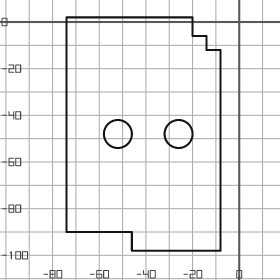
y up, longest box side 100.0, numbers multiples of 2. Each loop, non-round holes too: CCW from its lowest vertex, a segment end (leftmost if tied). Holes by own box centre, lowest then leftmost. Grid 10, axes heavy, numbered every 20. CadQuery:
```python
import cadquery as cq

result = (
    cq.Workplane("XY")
    .moveTo(-46.0, -98.0)
    .lineTo(-8.0, -98.0)
    .lineTo(-8.0, -12.0)
    .lineTo(-14.0, -12.0)
    .lineTo(-14.0, -6.0)
    .lineTo(-20.0, -6.0)
    .lineTo(-20.0, 2.0)
    .lineTo(-74.0, 2.0)
    .lineTo(-74.0, -90.0)
    .lineTo(-46.0, -90.0)
    .close()
    .moveTo(-52.0, -48.0)
    .circle(6.0)
    .moveTo(-26.0, -48.0)
    .circle(6.0)
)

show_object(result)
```